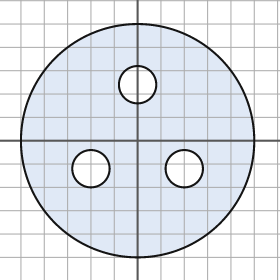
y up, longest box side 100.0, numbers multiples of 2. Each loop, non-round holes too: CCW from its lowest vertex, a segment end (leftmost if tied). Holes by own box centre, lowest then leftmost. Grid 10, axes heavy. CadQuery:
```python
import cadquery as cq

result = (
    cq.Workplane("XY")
    .moveTo(0.0, 0.0)
    .circle(50.0)
    .moveTo(-20.0, -12.0)
    .circle(8.0)
    .moveTo(20.0, -12.0)
    .circle(8.0)
    .moveTo(0.0, 24.0)
    .circle(8.0)
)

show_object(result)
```